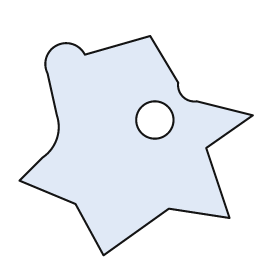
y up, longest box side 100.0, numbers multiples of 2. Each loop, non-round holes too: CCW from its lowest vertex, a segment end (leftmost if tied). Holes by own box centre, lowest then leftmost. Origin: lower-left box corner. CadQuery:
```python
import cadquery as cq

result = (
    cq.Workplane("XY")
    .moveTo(36.0, 0.0)
    .lineTo(64.0, 20.0)
    .lineTo(90.0, 16.0)
    .lineTo(80.0, 46.0)
    .lineTo(100.0, 60.0)
    .lineTo(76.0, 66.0)
    .threePointArc((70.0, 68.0), (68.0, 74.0))
    .lineTo(56.0, 94.0)
    .lineTo(28.0, 86.0)
    .threePointArc((16.0, 90.0), (12.0, 78.0))
    .lineTo(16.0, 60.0)
    .threePointArc((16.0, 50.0), (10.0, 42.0))
    .lineTo(0.0, 32.0)
    .lineTo(24.0, 22.0)
    .close()
    .moveTo(58.0, 58.0)
    .circle(8.0)
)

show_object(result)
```